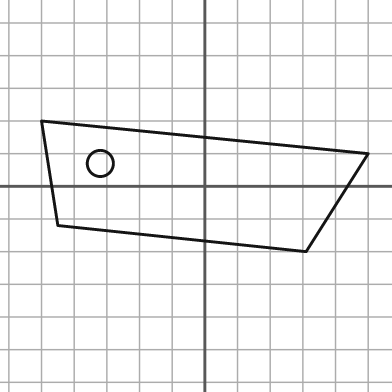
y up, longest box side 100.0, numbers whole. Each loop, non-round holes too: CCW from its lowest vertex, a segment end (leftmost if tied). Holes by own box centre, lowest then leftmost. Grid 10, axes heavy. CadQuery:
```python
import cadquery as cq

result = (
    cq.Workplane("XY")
    .moveTo(31.0, -20.0)
    .lineTo(50.0, 10.0)
    .lineTo(-50.0, 20.0)
    .lineTo(-45.0, -12.0)
    .close()
    .moveTo(-32.0, 7.0)
    .circle(4.0)
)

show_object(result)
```